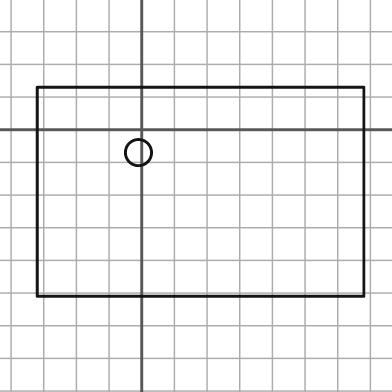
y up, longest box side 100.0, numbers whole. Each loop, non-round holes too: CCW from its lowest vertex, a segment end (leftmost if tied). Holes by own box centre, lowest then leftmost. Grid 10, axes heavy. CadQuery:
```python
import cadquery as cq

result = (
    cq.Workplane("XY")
    .moveTo(-32.0, -51.0)
    .lineTo(68.0, -51.0)
    .lineTo(68.0, 13.0)
    .lineTo(-32.0, 13.0)
    .close()
    .moveTo(-1.0, -7.0)
    .circle(4.0)
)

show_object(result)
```